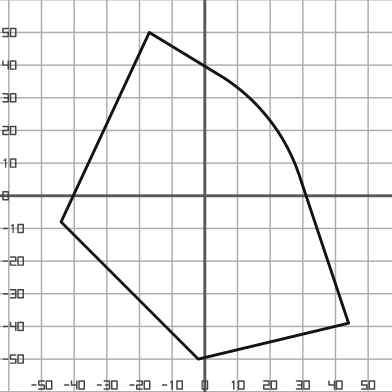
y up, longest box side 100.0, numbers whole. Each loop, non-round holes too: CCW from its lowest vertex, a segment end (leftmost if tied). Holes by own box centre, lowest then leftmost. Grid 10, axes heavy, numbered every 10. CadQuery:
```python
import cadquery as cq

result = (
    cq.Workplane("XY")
    .moveTo(-2.0, -50.0)
    .lineTo(44.0, -39.0)
    .lineTo(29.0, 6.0)
    .threePointArc((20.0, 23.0), (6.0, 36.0))
    .lineTo(-17.0, 50.0)
    .lineTo(-44.0, -8.0)
    .close()
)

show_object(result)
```